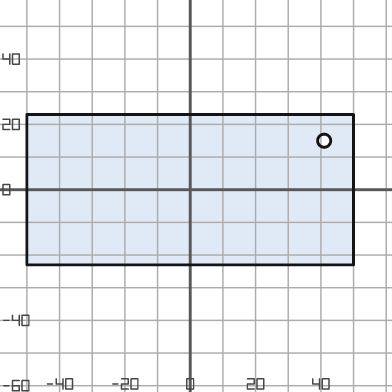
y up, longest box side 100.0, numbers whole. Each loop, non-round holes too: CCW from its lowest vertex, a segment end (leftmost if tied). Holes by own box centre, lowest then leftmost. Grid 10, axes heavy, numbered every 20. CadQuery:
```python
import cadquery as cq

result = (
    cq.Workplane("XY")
    .moveTo(-50.0, -23.0)
    .lineTo(50.0, -23.0)
    .lineTo(50.0, 23.0)
    .lineTo(-50.0, 23.0)
    .close()
    .moveTo(41.0, 15.0)
    .circle(2.0)
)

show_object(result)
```